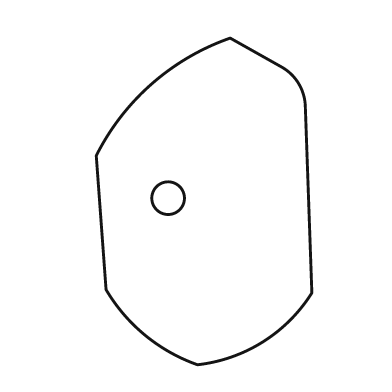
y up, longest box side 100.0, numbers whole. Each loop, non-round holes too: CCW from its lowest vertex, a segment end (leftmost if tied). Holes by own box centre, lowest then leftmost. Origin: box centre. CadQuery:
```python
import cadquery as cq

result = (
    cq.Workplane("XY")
    .moveTo(-2.0, -50.0)
    .threePointArc((18.0, -43.0), (33.0, -28.0))
    .lineTo(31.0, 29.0)
    .threePointArc((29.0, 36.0), (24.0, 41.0))
    .lineTo(8.0, 50.0)
    .threePointArc((-16.0, 36.0), (-33.0, 14.0))
    .lineTo(-30.0, -27.0)
    .threePointArc((-18.0, -41.0), (-2.0, -50.0))
    .close()
    .moveTo(-11.0, 1.0)
    .circle(5.0)
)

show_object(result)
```